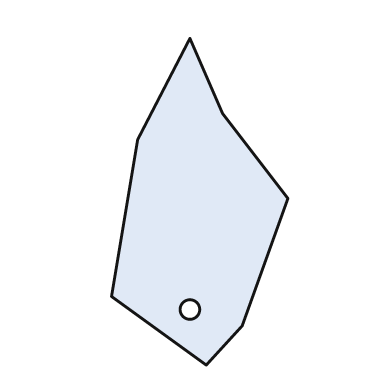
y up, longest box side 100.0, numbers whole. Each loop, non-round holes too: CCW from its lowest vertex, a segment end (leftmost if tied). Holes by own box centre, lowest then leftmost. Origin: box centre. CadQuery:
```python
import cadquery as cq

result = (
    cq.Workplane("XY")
    .moveTo(2.0, -50.0)
    .lineTo(13.0, -38.0)
    .lineTo(27.0, 1.0)
    .lineTo(7.0, 27.0)
    .lineTo(-3.0, 50.0)
    .lineTo(-19.0, 19.0)
    .lineTo(-27.0, -29.0)
    .close()
    .moveTo(-3.0, -33.0)
    .circle(3.0)
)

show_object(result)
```